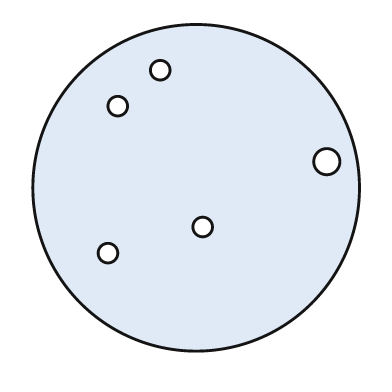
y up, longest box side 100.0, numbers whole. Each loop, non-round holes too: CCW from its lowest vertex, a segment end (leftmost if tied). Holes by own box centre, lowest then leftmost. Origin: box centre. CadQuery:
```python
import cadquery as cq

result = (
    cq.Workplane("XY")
    .moveTo(0.0, 0.0)
    .circle(50.0)
    .moveTo(-27.0, -20.0)
    .circle(3.0)
    .moveTo(2.0, -12.0)
    .circle(3.0)
    .moveTo(40.0, 8.0)
    .circle(4.0)
    .moveTo(-24.0, 25.0)
    .circle(3.0)
    .moveTo(-11.0, 36.0)
    .circle(3.0)
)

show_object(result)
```